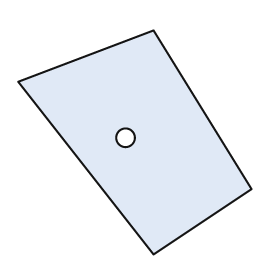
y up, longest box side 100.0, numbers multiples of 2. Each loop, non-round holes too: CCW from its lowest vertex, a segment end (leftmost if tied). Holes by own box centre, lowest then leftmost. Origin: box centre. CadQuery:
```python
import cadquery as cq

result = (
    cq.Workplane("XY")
    .moveTo(8.0, -48.0)
    .lineTo(50.0, -20.0)
    .lineTo(8.0, 48.0)
    .lineTo(-50.0, 26.0)
    .close()
    .moveTo(-4.0, 2.0)
    .circle(4.0)
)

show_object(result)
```